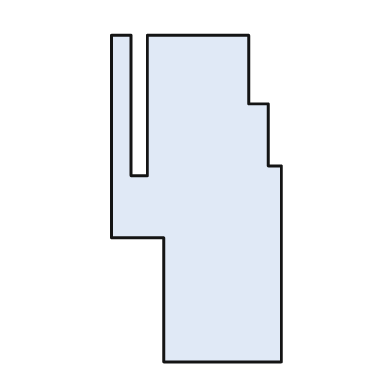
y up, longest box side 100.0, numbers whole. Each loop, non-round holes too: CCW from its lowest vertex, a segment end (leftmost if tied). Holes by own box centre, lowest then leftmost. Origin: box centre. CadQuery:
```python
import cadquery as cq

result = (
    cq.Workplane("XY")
    .moveTo(-10.0, -50.0)
    .lineTo(26.0, -50.0)
    .lineTo(26.0, 10.0)
    .lineTo(22.0, 10.0)
    .lineTo(22.0, 29.0)
    .lineTo(16.0, 29.0)
    .lineTo(16.0, 50.0)
    .lineTo(-15.0, 50.0)
    .lineTo(-15.0, 7.0)
    .lineTo(-20.0, 7.0)
    .lineTo(-20.0, 50.0)
    .lineTo(-26.0, 50.0)
    .lineTo(-26.0, -12.0)
    .lineTo(-10.0, -12.0)
    .close()
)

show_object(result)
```